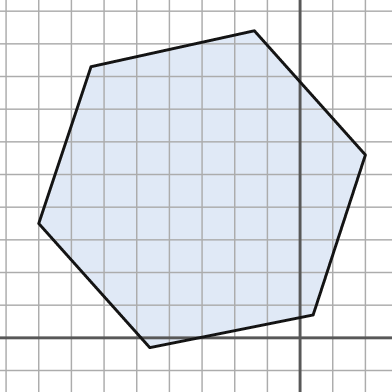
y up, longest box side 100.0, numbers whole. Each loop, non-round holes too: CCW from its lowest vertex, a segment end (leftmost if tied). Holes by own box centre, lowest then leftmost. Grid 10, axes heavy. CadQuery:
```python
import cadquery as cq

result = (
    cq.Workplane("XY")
    .moveTo(-46.0, -3.0)
    .lineTo(4.0, 7.0)
    .lineTo(20.0, 56.0)
    .lineTo(-14.0, 94.0)
    .lineTo(-64.0, 83.0)
    .lineTo(-80.0, 35.0)
    .close()
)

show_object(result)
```